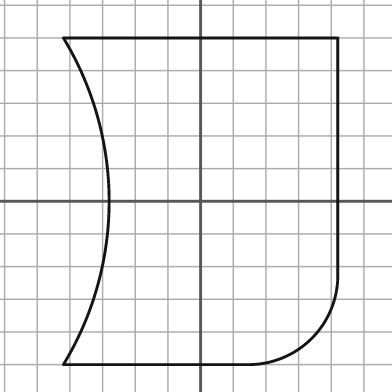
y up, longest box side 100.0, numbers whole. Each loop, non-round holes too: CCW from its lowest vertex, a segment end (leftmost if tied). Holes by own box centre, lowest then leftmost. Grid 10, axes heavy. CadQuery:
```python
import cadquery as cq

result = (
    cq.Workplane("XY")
    .moveTo(-42.0, -50.0)
    .lineTo(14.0, -50.0)
    .threePointArc((34.0, -42.0), (42.0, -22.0))
    .lineTo(42.0, 50.0)
    .lineTo(-42.0, 50.0)
    .threePointArc((-28.0, 0.0), (-42.0, -50.0))
    .close()
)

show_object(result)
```